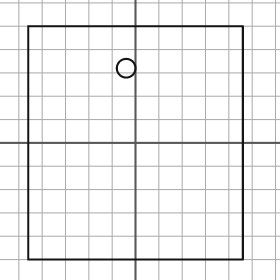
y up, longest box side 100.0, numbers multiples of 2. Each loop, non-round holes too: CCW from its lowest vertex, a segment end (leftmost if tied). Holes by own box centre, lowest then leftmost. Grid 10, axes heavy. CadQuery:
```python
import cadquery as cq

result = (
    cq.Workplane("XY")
    .moveTo(-46.0, -50.0)
    .lineTo(46.0, -50.0)
    .lineTo(46.0, 50.0)
    .lineTo(-46.0, 50.0)
    .close()
    .moveTo(-4.0, 32.0)
    .circle(4.0)
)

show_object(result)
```